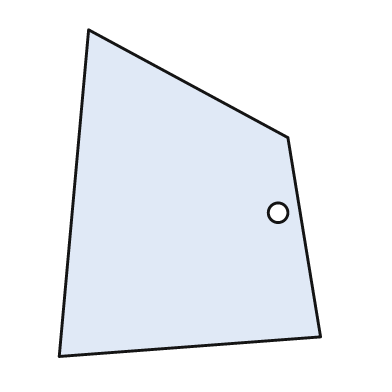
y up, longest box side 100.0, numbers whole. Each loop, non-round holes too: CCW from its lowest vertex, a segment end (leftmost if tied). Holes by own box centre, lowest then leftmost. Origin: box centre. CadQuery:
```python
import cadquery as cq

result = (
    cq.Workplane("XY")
    .moveTo(-40.0, -50.0)
    .lineTo(40.0, -44.0)
    .lineTo(30.0, 17.0)
    .lineTo(-31.0, 50.0)
    .close()
    .moveTo(27.0, -6.0)
    .circle(3.0)
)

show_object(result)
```